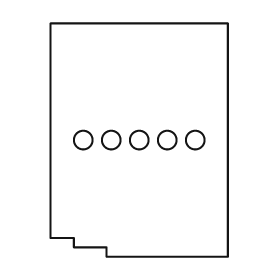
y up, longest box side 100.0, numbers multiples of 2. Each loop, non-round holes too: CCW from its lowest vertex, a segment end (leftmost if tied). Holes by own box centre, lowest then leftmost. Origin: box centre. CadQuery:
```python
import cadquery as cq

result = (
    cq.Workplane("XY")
    .moveTo(-14.0, -50.0)
    .lineTo(38.0, -50.0)
    .lineTo(38.0, 50.0)
    .lineTo(-38.0, 50.0)
    .lineTo(-38.0, -42.0)
    .lineTo(-28.0, -42.0)
    .lineTo(-28.0, -46.0)
    .lineTo(-14.0, -46.0)
    .close()
    .moveTo(-24.0, 0.0)
    .circle(4.0)
    .moveTo(-12.0, 0.0)
    .circle(4.0)
    .moveTo(0.0, 0.0)
    .circle(4.0)
    .moveTo(12.0, 0.0)
    .circle(4.0)
    .moveTo(24.0, 0.0)
    .circle(4.0)
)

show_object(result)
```